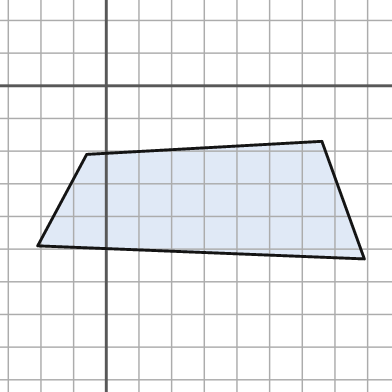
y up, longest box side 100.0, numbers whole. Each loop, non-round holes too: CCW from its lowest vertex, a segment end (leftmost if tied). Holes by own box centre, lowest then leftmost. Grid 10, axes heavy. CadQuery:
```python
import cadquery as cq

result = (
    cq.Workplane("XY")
    .moveTo(79.0, -53.0)
    .lineTo(66.0, -17.0)
    .lineTo(-6.0, -21.0)
    .lineTo(-21.0, -49.0)
    .close()
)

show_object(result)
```